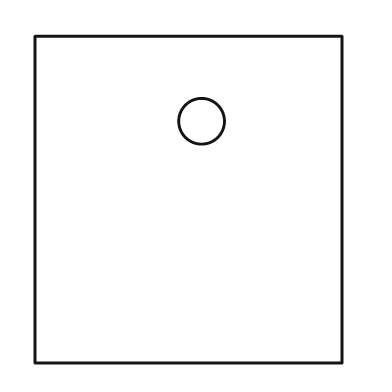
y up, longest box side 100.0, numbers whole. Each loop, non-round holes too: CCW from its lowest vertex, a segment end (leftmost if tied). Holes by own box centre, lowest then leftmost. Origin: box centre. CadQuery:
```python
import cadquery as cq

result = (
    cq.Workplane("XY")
    .moveTo(-47.0, -50.0)
    .lineTo(47.0, -50.0)
    .lineTo(47.0, 50.0)
    .lineTo(-47.0, 50.0)
    .close()
    .moveTo(4.0, 24.0)
    .circle(7.0)
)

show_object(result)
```